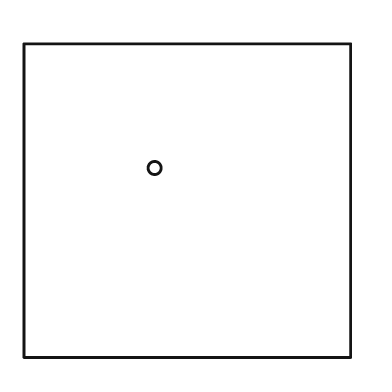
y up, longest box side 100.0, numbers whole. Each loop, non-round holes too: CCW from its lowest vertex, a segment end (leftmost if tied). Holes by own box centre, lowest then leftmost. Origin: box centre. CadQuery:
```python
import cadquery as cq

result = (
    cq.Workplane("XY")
    .moveTo(-50.0, -48.0)
    .lineTo(50.0, -48.0)
    .lineTo(50.0, 48.0)
    .lineTo(-50.0, 48.0)
    .close()
    .moveTo(-10.0, 10.0)
    .circle(2.0)
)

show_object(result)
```